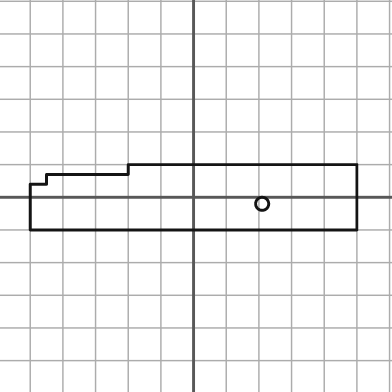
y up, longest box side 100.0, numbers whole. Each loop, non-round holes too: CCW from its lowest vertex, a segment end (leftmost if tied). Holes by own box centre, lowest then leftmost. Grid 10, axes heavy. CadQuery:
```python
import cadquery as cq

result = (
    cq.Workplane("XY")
    .moveTo(-50.0, -10.0)
    .lineTo(50.0, -10.0)
    .lineTo(50.0, 10.0)
    .lineTo(-20.0, 10.0)
    .lineTo(-20.0, 7.0)
    .lineTo(-45.0, 7.0)
    .lineTo(-45.0, 4.0)
    .lineTo(-50.0, 4.0)
    .close()
    .moveTo(21.0, -2.0)
    .circle(2.0)
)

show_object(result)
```